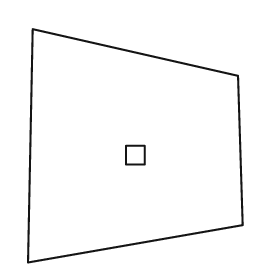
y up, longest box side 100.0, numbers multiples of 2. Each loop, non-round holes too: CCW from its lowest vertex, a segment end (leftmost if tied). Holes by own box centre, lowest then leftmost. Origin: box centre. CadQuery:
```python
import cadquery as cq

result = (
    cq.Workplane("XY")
    .moveTo(-46.0, -50.0)
    .lineTo(46.0, -34.0)
    .lineTo(44.0, 30.0)
    .lineTo(-44.0, 50.0)
    .close()
    .moveTo(-4.0, -8.0)
    .lineTo(4.0, -8.0)
    .lineTo(4.0, 0.0)
    .lineTo(-4.0, 0.0)
    .close()
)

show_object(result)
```